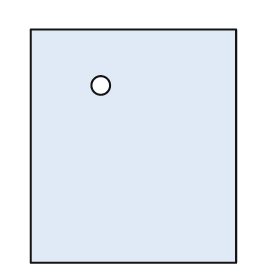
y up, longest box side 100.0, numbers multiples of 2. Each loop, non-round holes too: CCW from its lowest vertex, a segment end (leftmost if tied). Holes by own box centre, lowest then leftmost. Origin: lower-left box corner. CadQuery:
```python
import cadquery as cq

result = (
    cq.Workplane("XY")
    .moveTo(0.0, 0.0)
    .lineTo(88.0, 0.0)
    .lineTo(88.0, 100.0)
    .lineTo(0.0, 100.0)
    .close()
    .moveTo(30.0, 76.0)
    .circle(4.0)
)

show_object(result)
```